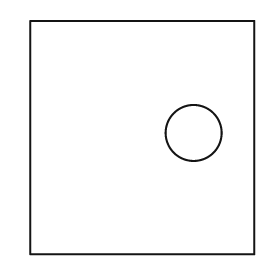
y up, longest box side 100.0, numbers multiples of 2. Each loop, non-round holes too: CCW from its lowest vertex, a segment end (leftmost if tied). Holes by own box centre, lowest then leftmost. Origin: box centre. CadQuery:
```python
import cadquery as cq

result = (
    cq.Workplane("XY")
    .moveTo(-48.0, -50.0)
    .lineTo(48.0, -50.0)
    .lineTo(48.0, 50.0)
    .lineTo(-48.0, 50.0)
    .close()
    .moveTo(22.0, 2.0)
    .circle(12.0)
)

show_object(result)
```